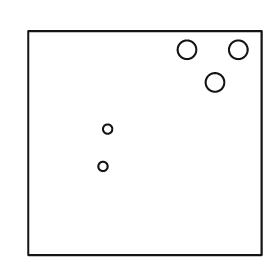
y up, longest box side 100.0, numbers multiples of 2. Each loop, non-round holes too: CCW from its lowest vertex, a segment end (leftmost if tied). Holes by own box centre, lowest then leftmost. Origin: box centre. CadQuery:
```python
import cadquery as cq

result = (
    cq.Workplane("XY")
    .moveTo(-50.0, -48.0)
    .lineTo(50.0, -48.0)
    .lineTo(50.0, 48.0)
    .lineTo(-50.0, 48.0)
    .close()
    .moveTo(-18.0, -10.0)
    .circle(2.0)
    .moveTo(-16.0, 6.0)
    .circle(2.0)
    .moveTo(30.0, 26.0)
    .circle(4.0)
    .moveTo(18.0, 40.0)
    .circle(4.0)
    .moveTo(40.0, 40.0)
    .circle(4.0)
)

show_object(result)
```